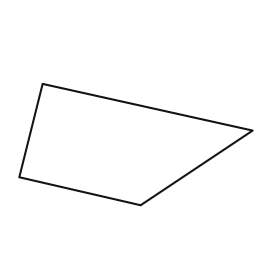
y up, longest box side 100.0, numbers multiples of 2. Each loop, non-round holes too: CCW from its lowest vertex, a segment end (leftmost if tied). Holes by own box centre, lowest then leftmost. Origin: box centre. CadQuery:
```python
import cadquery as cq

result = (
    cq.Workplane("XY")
    .moveTo(2.0, -26.0)
    .lineTo(50.0, 6.0)
    .lineTo(-40.0, 26.0)
    .lineTo(-50.0, -14.0)
    .close()
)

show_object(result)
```